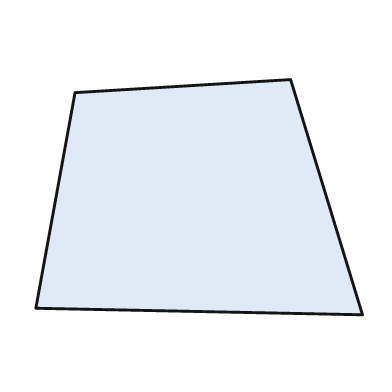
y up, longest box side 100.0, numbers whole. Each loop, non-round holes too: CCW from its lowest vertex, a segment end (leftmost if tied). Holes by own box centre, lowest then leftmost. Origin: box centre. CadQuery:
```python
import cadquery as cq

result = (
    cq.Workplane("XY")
    .moveTo(50.0, -36.0)
    .lineTo(28.0, 36.0)
    .lineTo(-38.0, 32.0)
    .lineTo(-50.0, -34.0)
    .close()
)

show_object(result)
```